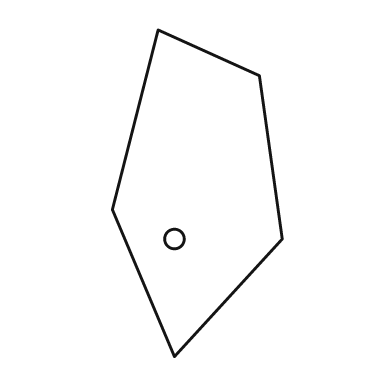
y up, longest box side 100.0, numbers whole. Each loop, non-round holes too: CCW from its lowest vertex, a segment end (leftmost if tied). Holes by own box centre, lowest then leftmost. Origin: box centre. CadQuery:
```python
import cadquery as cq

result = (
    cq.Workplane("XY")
    .moveTo(-7.0, -50.0)
    .lineTo(26.0, -14.0)
    .lineTo(19.0, 36.0)
    .lineTo(-12.0, 50.0)
    .lineTo(-26.0, -5.0)
    .close()
    .moveTo(-7.0, -14.0)
    .circle(3.0)
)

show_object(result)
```